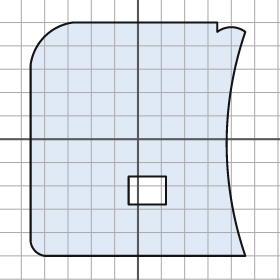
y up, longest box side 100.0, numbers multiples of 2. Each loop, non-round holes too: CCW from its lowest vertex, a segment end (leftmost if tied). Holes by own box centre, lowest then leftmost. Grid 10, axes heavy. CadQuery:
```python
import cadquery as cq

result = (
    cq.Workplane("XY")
    .moveTo(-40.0, -50.0)
    .lineTo(46.0, -50.0)
    .threePointArc((38.0, -2.0), (46.0, 46.0))
    .threePointArc((40.0, 48.0), (34.0, 46.0))
    .lineTo(34.0, 50.0)
    .lineTo(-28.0, 50.0)
    .threePointArc((-40.0, 44.0), (-46.0, 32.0))
    .lineTo(-46.0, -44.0)
    .threePointArc((-44.0, -48.0), (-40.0, -50.0))
    .close()
    .moveTo(-4.0, -28.0)
    .lineTo(12.0, -28.0)
    .lineTo(12.0, -16.0)
    .lineTo(-4.0, -16.0)
    .close()
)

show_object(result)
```